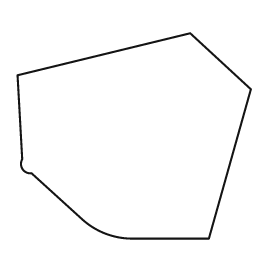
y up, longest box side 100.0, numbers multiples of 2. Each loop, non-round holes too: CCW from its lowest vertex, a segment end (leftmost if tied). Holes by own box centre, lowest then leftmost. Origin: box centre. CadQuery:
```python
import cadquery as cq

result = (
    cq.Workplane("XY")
    .moveTo(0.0, -44.0)
    .lineTo(32.0, -44.0)
    .lineTo(50.0, 20.0)
    .lineTo(24.0, 44.0)
    .lineTo(-50.0, 26.0)
    .lineTo(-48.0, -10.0)
    .threePointArc((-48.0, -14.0), (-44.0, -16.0))
    .lineTo(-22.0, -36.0)
    .threePointArc((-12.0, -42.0), (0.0, -44.0))
    .close()
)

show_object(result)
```